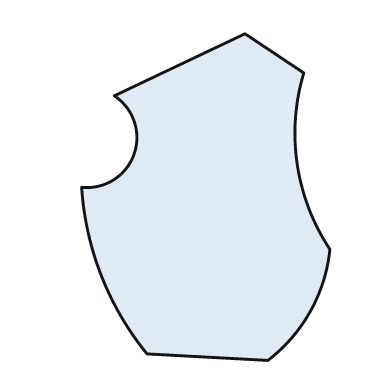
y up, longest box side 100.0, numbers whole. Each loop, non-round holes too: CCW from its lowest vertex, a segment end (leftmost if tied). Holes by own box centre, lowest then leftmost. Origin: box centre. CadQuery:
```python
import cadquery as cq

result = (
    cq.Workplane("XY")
    .moveTo(19.0, -50.0)
    .threePointArc((32.0, -35.0), (38.0, -16.0))
    .threePointArc((28.0, 10.0), (30.0, 38.0))
    .lineTo(12.0, 50.0)
    .lineTo(-28.0, 31.0)
    .threePointArc((-22.0, 13.0), (-38.0, 3.0))
    .threePointArc((-32.0, -24.0), (-18.0, -48.0))
    .close()
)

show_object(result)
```